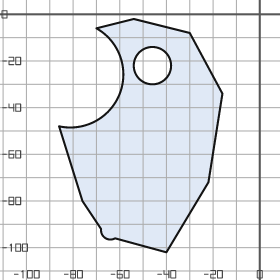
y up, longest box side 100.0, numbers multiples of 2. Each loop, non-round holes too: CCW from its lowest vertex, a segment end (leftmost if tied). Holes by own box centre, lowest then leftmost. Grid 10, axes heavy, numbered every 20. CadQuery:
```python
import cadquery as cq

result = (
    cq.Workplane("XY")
    .moveTo(-40.0, -102.0)
    .lineTo(-22.0, -72.0)
    .lineTo(-16.0, -34.0)
    .lineTo(-30.0, -8.0)
    .lineTo(-54.0, -2.0)
    .lineTo(-70.0, -6.0)
    .threePointArc((-60.0, -34.0), (-86.0, -48.0))
    .lineTo(-76.0, -80.0)
    .lineTo(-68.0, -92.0)
    .threePointArc((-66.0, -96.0), (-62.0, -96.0))
    .close()
    .moveTo(-46.0, -22.0)
    .circle(8.0)
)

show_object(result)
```